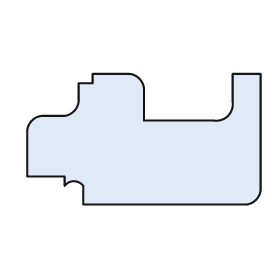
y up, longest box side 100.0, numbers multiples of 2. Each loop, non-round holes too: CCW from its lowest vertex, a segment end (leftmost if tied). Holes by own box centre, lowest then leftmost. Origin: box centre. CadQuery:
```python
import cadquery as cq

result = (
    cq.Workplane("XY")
    .moveTo(-26.0, -28.0)
    .lineTo(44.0, -28.0)
    .threePointArc((48.0, -26.0), (50.0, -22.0))
    .lineTo(50.0, 28.0)
    .lineTo(38.0, 28.0)
    .lineTo(38.0, 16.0)
    .threePointArc((36.0, 10.0), (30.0, 8.0))
    .lineTo(0.0, 8.0)
    .lineTo(0.0, 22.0)
    .threePointArc((-2.0, 26.0), (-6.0, 28.0))
    .lineTo(-22.0, 28.0)
    .lineTo(-22.0, 24.0)
    .lineTo(-28.0, 24.0)
    .lineTo(-28.0, 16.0)
    .threePointArc((-30.0, 12.0), (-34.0, 10.0))
    .lineTo(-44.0, 10.0)
    .threePointArc((-48.0, 8.0), (-50.0, 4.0))
    .lineTo(-50.0, -16.0)
    .lineTo(-34.0, -16.0)
    .lineTo(-34.0, -20.0)
    .threePointArc((-30.0, -18.0), (-26.0, -20.0))
    .close()
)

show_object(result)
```